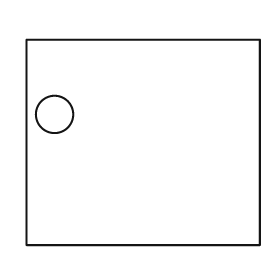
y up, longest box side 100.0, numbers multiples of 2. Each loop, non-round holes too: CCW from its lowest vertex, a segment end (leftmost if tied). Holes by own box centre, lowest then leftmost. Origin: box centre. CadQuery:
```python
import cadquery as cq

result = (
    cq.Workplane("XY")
    .moveTo(-50.0, -44.0)
    .lineTo(50.0, -44.0)
    .lineTo(50.0, 44.0)
    .lineTo(-50.0, 44.0)
    .close()
    .moveTo(-38.0, 12.0)
    .circle(8.0)
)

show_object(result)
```